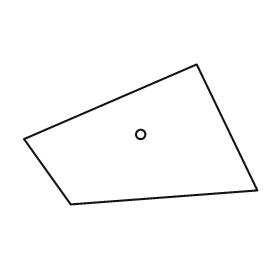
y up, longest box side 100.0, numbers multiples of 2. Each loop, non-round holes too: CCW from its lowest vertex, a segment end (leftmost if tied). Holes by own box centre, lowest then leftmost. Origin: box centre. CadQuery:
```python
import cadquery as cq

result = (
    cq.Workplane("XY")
    .moveTo(-30.0, -30.0)
    .lineTo(50.0, -24.0)
    .lineTo(24.0, 30.0)
    .lineTo(-50.0, -2.0)
    .close()
    .moveTo(0.0, 0.0)
    .circle(2.0)
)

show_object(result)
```